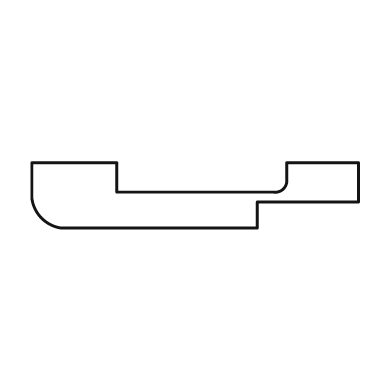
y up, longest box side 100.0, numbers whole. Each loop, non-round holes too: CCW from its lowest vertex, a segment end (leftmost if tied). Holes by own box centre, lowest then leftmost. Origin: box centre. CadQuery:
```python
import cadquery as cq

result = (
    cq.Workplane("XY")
    .moveTo(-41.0, -10.0)
    .lineTo(19.0, -10.0)
    .lineTo(19.0, -2.0)
    .lineTo(50.0, -2.0)
    .lineTo(50.0, 10.0)
    .lineTo(28.0, 10.0)
    .lineTo(28.0, 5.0)
    .threePointArc((27.0, 2.0), (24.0, 1.0))
    .lineTo(-24.0, 1.0)
    .lineTo(-24.0, 10.0)
    .lineTo(-50.0, 10.0)
    .lineTo(-50.0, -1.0)
    .threePointArc((-47.0, -7.0), (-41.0, -10.0))
    .close()
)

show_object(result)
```